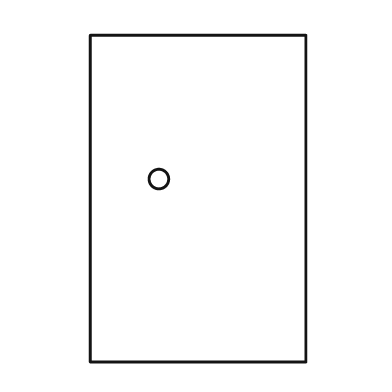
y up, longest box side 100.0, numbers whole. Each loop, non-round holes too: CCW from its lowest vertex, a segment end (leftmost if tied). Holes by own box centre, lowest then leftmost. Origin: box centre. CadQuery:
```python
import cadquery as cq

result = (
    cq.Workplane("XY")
    .moveTo(-33.0, -50.0)
    .lineTo(33.0, -50.0)
    .lineTo(33.0, 50.0)
    .lineTo(-33.0, 50.0)
    .close()
    .moveTo(-12.0, 6.0)
    .circle(3.0)
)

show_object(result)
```